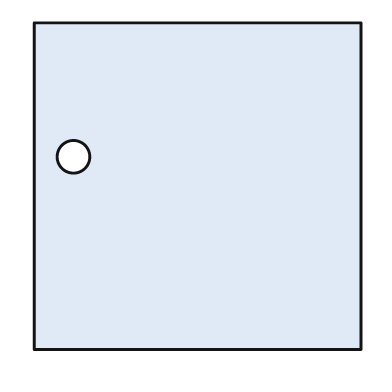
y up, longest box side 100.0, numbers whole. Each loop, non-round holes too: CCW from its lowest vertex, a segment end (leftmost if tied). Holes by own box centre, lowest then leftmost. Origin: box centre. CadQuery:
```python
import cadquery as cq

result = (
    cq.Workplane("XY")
    .moveTo(-50.0, -50.0)
    .lineTo(50.0, -50.0)
    .lineTo(50.0, 50.0)
    .lineTo(-50.0, 50.0)
    .close()
    .moveTo(-38.0, 9.0)
    .circle(5.0)
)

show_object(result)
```